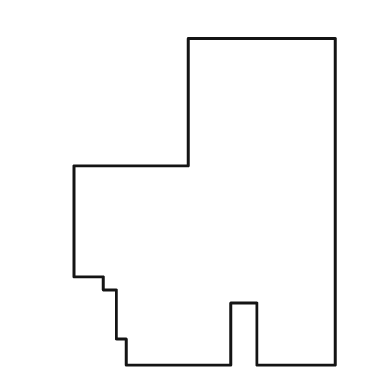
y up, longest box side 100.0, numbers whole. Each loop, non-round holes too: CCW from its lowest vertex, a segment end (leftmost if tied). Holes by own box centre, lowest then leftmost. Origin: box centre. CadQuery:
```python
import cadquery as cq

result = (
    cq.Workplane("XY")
    .moveTo(-24.0, -50.0)
    .lineTo(8.0, -50.0)
    .lineTo(8.0, -31.0)
    .lineTo(16.0, -31.0)
    .lineTo(16.0, -50.0)
    .lineTo(40.0, -50.0)
    .lineTo(40.0, 50.0)
    .lineTo(-5.0, 50.0)
    .lineTo(-5.0, 11.0)
    .lineTo(-40.0, 11.0)
    .lineTo(-40.0, -23.0)
    .lineTo(-31.0, -23.0)
    .lineTo(-31.0, -27.0)
    .lineTo(-27.0, -27.0)
    .lineTo(-27.0, -42.0)
    .lineTo(-24.0, -42.0)
    .close()
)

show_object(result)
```